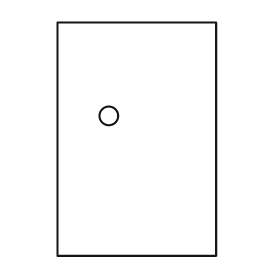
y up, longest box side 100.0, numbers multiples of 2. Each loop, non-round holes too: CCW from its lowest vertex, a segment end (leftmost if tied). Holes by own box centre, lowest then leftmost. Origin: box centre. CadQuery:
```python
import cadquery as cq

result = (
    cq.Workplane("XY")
    .moveTo(-34.0, -50.0)
    .lineTo(34.0, -50.0)
    .lineTo(34.0, 50.0)
    .lineTo(-34.0, 50.0)
    .close()
    .moveTo(-12.0, 10.0)
    .circle(4.0)
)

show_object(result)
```